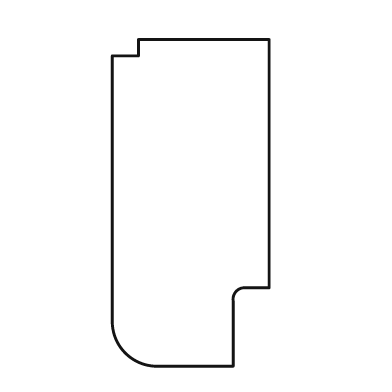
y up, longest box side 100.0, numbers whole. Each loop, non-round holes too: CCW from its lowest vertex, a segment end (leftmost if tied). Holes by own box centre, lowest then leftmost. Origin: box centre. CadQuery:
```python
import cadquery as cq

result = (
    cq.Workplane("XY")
    .moveTo(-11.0, -50.0)
    .lineTo(13.0, -50.0)
    .lineTo(13.0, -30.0)
    .threePointArc((14.0, -27.0), (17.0, -26.0))
    .lineTo(24.0, -26.0)
    .lineTo(24.0, 50.0)
    .lineTo(-16.0, 50.0)
    .lineTo(-16.0, 45.0)
    .lineTo(-24.0, 45.0)
    .lineTo(-24.0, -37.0)
    .threePointArc((-20.0, -46.0), (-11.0, -50.0))
    .close()
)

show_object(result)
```